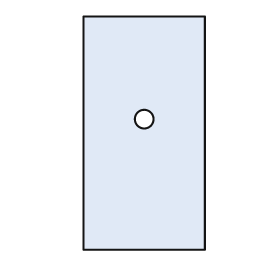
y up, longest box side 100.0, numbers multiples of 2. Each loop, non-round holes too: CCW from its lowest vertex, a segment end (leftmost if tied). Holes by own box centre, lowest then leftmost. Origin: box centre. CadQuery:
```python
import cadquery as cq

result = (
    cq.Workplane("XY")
    .moveTo(-26.0, -50.0)
    .lineTo(26.0, -50.0)
    .lineTo(26.0, 50.0)
    .lineTo(-26.0, 50.0)
    .close()
    .moveTo(0.0, 6.0)
    .circle(4.0)
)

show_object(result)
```